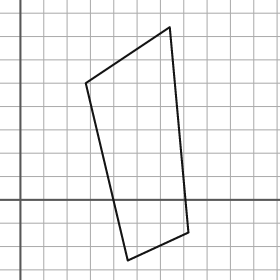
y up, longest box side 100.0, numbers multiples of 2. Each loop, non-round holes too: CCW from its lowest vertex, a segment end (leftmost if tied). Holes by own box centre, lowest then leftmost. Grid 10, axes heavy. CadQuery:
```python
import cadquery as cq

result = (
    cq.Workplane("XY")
    .moveTo(46.0, -26.0)
    .lineTo(72.0, -14.0)
    .lineTo(64.0, 74.0)
    .lineTo(28.0, 50.0)
    .close()
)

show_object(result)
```